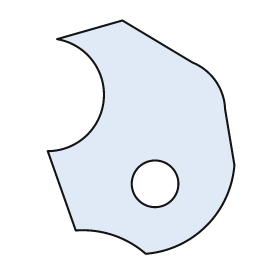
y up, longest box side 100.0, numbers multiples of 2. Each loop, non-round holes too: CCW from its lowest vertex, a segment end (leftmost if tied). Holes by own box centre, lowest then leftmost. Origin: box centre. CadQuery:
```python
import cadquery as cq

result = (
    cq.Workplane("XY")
    .moveTo(2.0, -50.0)
    .threePointArc((28.0, -38.0), (40.0, -12.0))
    .lineTo(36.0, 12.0)
    .threePointArc((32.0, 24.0), (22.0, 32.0))
    .lineTo(-8.0, 50.0)
    .lineTo(-36.0, 42.0)
    .threePointArc((-16.0, 16.0), (-40.0, -6.0))
    .lineTo(-28.0, -40.0)
    .threePointArc((-12.0, -42.0), (2.0, -50.0))
    .close()
    .moveTo(6.0, -20.0)
    .circle(10.0)
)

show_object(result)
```